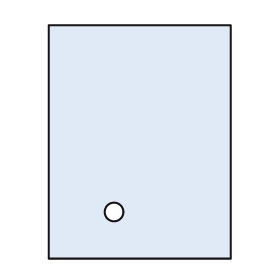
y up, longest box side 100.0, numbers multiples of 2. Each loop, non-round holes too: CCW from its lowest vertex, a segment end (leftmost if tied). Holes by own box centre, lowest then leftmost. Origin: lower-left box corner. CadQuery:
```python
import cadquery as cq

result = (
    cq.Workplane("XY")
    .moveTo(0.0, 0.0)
    .lineTo(78.0, 0.0)
    .lineTo(78.0, 100.0)
    .lineTo(0.0, 100.0)
    .close()
    .moveTo(28.0, 20.0)
    .circle(4.0)
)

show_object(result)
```